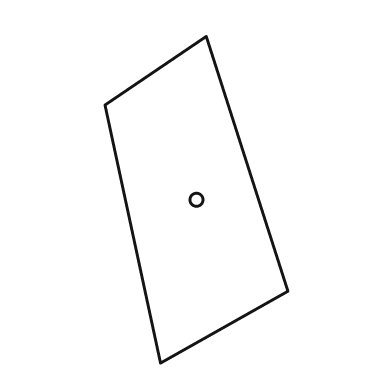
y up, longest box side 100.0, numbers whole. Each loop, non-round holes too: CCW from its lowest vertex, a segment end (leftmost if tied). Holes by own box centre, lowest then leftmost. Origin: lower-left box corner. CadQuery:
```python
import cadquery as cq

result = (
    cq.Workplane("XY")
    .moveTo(17.0, 0.0)
    .lineTo(56.0, 22.0)
    .lineTo(31.0, 100.0)
    .lineTo(0.0, 79.0)
    .close()
    .moveTo(28.0, 50.0)
    .circle(2.0)
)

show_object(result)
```